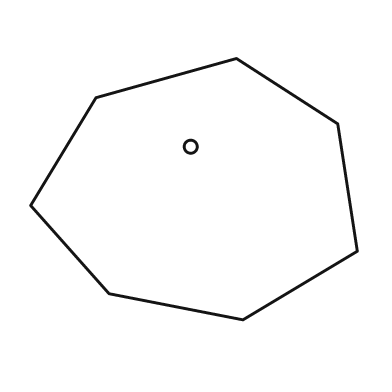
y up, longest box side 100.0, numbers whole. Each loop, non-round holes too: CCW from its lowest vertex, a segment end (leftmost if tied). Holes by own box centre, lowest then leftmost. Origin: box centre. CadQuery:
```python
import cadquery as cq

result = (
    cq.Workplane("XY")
    .moveTo(15.0, -40.0)
    .lineTo(50.0, -19.0)
    .lineTo(44.0, 20.0)
    .lineTo(13.0, 40.0)
    .lineTo(-30.0, 28.0)
    .lineTo(-50.0, -5.0)
    .lineTo(-26.0, -32.0)
    .close()
    .moveTo(-1.0, 13.0)
    .circle(2.0)
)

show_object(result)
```